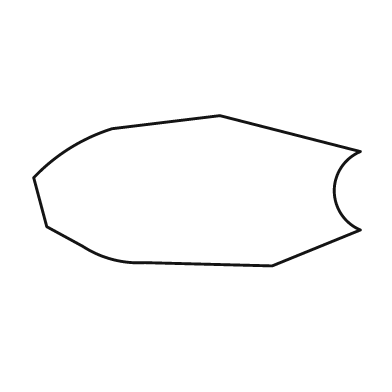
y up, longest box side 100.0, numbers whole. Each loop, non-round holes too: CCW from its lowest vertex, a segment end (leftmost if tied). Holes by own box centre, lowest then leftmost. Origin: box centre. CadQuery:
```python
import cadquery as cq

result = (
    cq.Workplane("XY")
    .moveTo(23.0, -23.0)
    .lineTo(50.0, -12.0)
    .threePointArc((42.0, 0.0), (50.0, 12.0))
    .lineTo(7.0, 23.0)
    .lineTo(-26.0, 19.0)
    .threePointArc((-39.0, 13.0), (-50.0, 4.0))
    .lineTo(-46.0, -11.0)
    .lineTo(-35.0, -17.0)
    .threePointArc((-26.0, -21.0), (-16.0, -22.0))
    .close()
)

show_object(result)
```